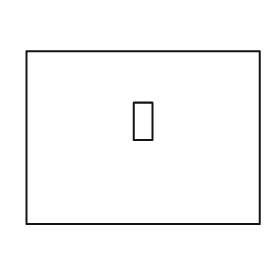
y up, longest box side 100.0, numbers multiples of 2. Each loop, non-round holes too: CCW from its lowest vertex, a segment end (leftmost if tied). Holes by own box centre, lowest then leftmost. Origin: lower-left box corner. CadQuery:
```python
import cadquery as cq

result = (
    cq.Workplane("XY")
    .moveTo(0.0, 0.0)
    .lineTo(100.0, 0.0)
    .lineTo(100.0, 74.0)
    .lineTo(0.0, 74.0)
    .close()
    .moveTo(46.0, 36.0)
    .lineTo(54.0, 36.0)
    .lineTo(54.0, 52.0)
    .lineTo(46.0, 52.0)
    .close()
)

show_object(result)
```